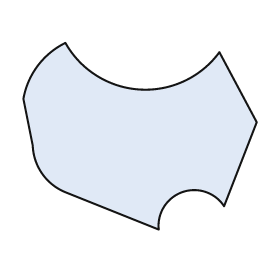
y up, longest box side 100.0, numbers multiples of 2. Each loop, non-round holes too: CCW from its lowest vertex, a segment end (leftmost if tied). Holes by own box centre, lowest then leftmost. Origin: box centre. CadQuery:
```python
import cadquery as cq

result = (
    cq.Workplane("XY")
    .moveTo(8.0, -40.0)
    .threePointArc((18.0, -24.0), (36.0, -30.0))
    .lineTo(50.0, 6.0)
    .lineTo(34.0, 36.0)
    .threePointArc((0.0, 20.0), (-32.0, 40.0))
    .threePointArc((-44.0, 30.0), (-50.0, 16.0))
    .lineTo(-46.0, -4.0)
    .threePointArc((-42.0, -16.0), (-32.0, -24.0))
    .close()
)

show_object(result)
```